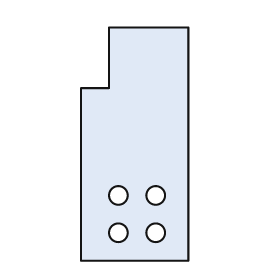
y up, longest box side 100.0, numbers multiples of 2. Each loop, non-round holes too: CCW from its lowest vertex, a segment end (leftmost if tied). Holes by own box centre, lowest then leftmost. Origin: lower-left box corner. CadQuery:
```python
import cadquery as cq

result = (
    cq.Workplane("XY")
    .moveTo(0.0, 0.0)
    .lineTo(46.0, 0.0)
    .lineTo(46.0, 100.0)
    .lineTo(12.0, 100.0)
    .lineTo(12.0, 74.0)
    .lineTo(0.0, 74.0)
    .close()
    .moveTo(16.0, 12.0)
    .circle(4.0)
    .moveTo(32.0, 12.0)
    .circle(4.0)
    .moveTo(16.0, 28.0)
    .circle(4.0)
    .moveTo(32.0, 28.0)
    .circle(4.0)
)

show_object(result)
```